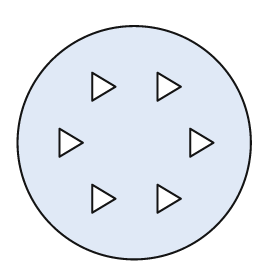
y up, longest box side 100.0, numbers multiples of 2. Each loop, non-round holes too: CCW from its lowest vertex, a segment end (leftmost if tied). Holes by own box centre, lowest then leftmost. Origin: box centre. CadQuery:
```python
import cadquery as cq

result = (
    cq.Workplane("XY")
    .moveTo(0.0, 0.0)
    .circle(50.0)
    .moveTo(-18.0, -30.0)
    .lineTo(-8.0, -24.0)
    .lineTo(-18.0, -18.0)
    .close()
    .moveTo(10.0, -30.0)
    .lineTo(20.0, -24.0)
    .lineTo(10.0, -18.0)
    .close()
    .moveTo(-32.0, -6.0)
    .lineTo(-22.0, 0.0)
    .lineTo(-32.0, 6.0)
    .close()
    .moveTo(24.0, -6.0)
    .lineTo(34.0, 0.0)
    .lineTo(24.0, 6.0)
    .close()
    .moveTo(-18.0, 18.0)
    .lineTo(-8.0, 24.0)
    .lineTo(-18.0, 30.0)
    .close()
    .moveTo(10.0, 18.0)
    .lineTo(20.0, 24.0)
    .lineTo(10.0, 30.0)
    .close()
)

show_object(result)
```